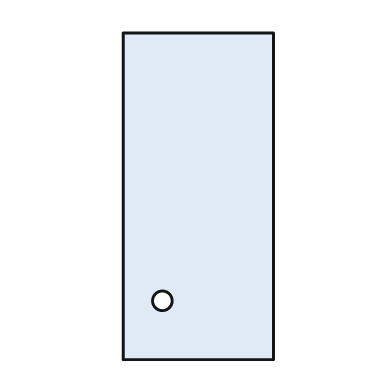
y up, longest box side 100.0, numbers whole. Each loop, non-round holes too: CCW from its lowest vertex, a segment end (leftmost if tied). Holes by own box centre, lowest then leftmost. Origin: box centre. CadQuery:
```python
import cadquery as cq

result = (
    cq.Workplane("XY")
    .moveTo(-23.0, -50.0)
    .lineTo(23.0, -50.0)
    .lineTo(23.0, 50.0)
    .lineTo(-23.0, 50.0)
    .close()
    .moveTo(-11.0, -32.0)
    .circle(3.0)
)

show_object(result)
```